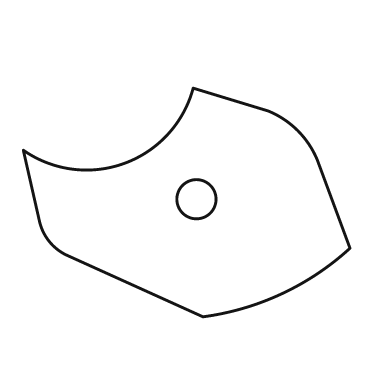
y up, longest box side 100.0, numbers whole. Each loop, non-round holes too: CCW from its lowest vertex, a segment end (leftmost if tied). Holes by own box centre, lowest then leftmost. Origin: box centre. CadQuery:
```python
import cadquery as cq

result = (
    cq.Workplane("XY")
    .moveTo(5.0, -35.0)
    .threePointArc((29.0, -28.0), (50.0, -14.0))
    .lineTo(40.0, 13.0)
    .threePointArc((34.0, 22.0), (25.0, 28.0))
    .lineTo(2.0, 35.0)
    .threePointArc((-19.0, 12.0), (-50.0, 16.0))
    .lineTo(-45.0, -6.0)
    .threePointArc((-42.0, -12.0), (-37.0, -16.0))
    .close()
    .moveTo(3.0, 1.0)
    .circle(6.0)
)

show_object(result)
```